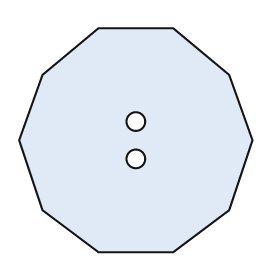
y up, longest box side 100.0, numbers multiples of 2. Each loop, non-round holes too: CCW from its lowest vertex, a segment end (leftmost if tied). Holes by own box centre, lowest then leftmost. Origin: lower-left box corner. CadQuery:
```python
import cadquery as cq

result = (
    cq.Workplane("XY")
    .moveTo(34.0, 0.0)
    .lineTo(66.0, 0.0)
    .lineTo(90.0, 18.0)
    .lineTo(100.0, 48.0)
    .lineTo(90.0, 76.0)
    .lineTo(66.0, 96.0)
    .lineTo(34.0, 96.0)
    .lineTo(10.0, 76.0)
    .lineTo(0.0, 48.0)
    .lineTo(10.0, 18.0)
    .close()
    .moveTo(50.0, 40.0)
    .circle(4.0)
    .moveTo(50.0, 56.0)
    .circle(4.0)
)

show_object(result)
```